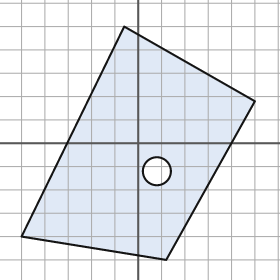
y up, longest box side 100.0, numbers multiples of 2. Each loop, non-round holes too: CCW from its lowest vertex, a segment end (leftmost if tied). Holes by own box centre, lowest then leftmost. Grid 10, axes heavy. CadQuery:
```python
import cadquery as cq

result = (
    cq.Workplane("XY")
    .moveTo(12.0, -50.0)
    .lineTo(50.0, 18.0)
    .lineTo(-6.0, 50.0)
    .lineTo(-50.0, -40.0)
    .close()
    .moveTo(8.0, -12.0)
    .circle(6.0)
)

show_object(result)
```